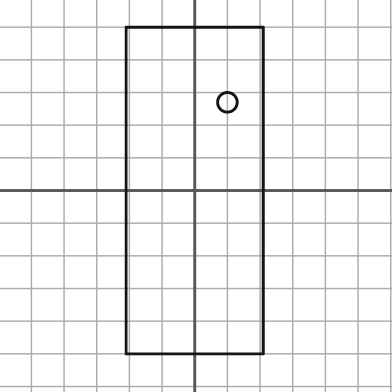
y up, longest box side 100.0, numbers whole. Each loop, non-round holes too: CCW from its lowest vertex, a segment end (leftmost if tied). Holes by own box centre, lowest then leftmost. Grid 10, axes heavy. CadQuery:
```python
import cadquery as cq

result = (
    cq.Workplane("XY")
    .moveTo(-21.0, -50.0)
    .lineTo(21.0, -50.0)
    .lineTo(21.0, 50.0)
    .lineTo(-21.0, 50.0)
    .close()
    .moveTo(10.0, 27.0)
    .circle(3.0)
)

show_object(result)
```